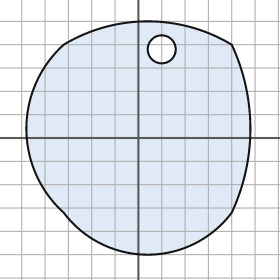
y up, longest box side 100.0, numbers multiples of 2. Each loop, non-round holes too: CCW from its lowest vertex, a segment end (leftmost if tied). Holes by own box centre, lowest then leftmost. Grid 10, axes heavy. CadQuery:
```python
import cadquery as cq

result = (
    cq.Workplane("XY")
    .moveTo(-32.0, -32.0)
    .threePointArc((4.0, -50.0), (40.0, -32.0))
    .threePointArc((48.0, 4.0), (40.0, 40.0))
    .threePointArc((4.0, 50.0), (-32.0, 40.0))
    .threePointArc((-48.0, 4.0), (-32.0, -32.0))
    .close()
    .moveTo(10.0, 38.0)
    .circle(6.0)
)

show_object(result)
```